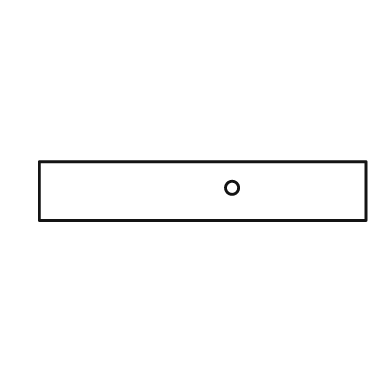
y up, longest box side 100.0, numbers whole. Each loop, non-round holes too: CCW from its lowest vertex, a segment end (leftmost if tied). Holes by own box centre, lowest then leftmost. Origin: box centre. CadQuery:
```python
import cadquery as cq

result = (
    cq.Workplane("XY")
    .moveTo(-50.0, -9.0)
    .lineTo(50.0, -9.0)
    .lineTo(50.0, 9.0)
    .lineTo(-50.0, 9.0)
    .close()
    .moveTo(9.0, 1.0)
    .circle(2.0)
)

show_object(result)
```